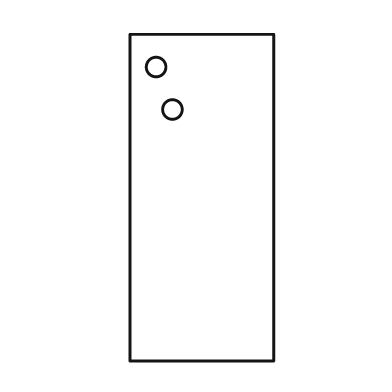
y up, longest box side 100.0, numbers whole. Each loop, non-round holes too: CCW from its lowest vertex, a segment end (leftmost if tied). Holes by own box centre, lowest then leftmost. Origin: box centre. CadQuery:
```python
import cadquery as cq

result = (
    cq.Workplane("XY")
    .moveTo(-22.0, -50.0)
    .lineTo(22.0, -50.0)
    .lineTo(22.0, 50.0)
    .lineTo(-22.0, 50.0)
    .close()
    .moveTo(-9.0, 27.0)
    .circle(3.0)
    .moveTo(-14.0, 40.0)
    .circle(3.0)
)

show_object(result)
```